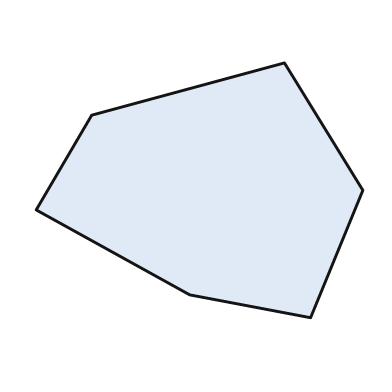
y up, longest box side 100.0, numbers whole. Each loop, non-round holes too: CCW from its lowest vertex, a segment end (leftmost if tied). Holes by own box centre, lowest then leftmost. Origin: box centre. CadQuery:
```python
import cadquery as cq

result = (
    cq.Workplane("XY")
    .moveTo(34.0, -39.0)
    .lineTo(50.0, 0.0)
    .lineTo(26.0, 39.0)
    .lineTo(-33.0, 23.0)
    .lineTo(-50.0, -6.0)
    .lineTo(-3.0, -32.0)
    .close()
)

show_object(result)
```